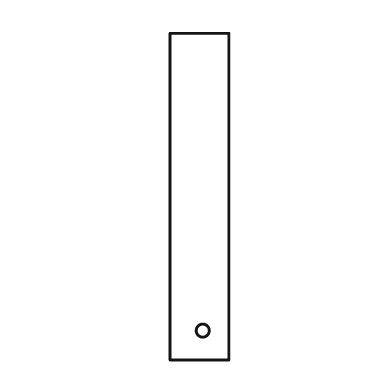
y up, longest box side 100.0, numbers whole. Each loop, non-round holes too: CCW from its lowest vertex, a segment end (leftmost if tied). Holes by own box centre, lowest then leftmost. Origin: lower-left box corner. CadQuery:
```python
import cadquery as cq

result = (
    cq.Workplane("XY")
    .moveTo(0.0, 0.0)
    .lineTo(18.0, 0.0)
    .lineTo(18.0, 100.0)
    .lineTo(0.0, 100.0)
    .close()
    .moveTo(10.0, 9.0)
    .circle(2.0)
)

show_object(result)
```